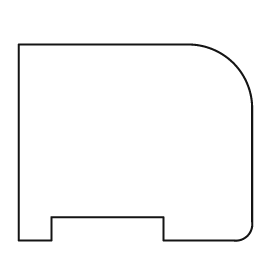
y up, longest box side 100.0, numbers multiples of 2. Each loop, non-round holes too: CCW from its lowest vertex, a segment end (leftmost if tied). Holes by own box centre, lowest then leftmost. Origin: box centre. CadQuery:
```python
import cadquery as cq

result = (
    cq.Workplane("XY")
    .moveTo(-50.0, -42.0)
    .lineTo(-36.0, -42.0)
    .lineTo(-36.0, -32.0)
    .lineTo(12.0, -32.0)
    .lineTo(12.0, -42.0)
    .lineTo(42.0, -42.0)
    .threePointArc((48.0, -40.0), (50.0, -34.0))
    .lineTo(50.0, 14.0)
    .threePointArc((42.0, 34.0), (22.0, 42.0))
    .lineTo(-50.0, 42.0)
    .close()
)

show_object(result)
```